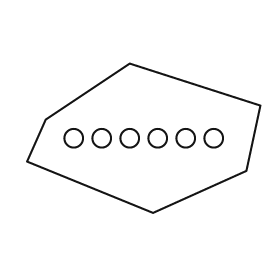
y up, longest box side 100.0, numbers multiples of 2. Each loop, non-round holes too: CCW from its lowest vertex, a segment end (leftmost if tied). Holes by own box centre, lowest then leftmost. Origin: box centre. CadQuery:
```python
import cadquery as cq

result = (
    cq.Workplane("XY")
    .moveTo(4.0, -32.0)
    .lineTo(44.0, -14.0)
    .lineTo(50.0, 14.0)
    .lineTo(-6.0, 32.0)
    .lineTo(-42.0, 8.0)
    .lineTo(-50.0, -10.0)
    .close()
    .moveTo(-30.0, 0.0)
    .circle(4.0)
    .moveTo(-18.0, 0.0)
    .circle(4.0)
    .moveTo(-6.0, 0.0)
    .circle(4.0)
    .moveTo(6.0, 0.0)
    .circle(4.0)
    .moveTo(18.0, 0.0)
    .circle(4.0)
    .moveTo(30.0, 0.0)
    .circle(4.0)
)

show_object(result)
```